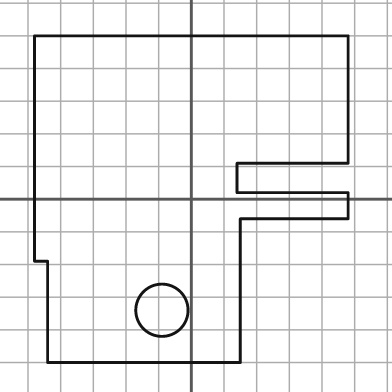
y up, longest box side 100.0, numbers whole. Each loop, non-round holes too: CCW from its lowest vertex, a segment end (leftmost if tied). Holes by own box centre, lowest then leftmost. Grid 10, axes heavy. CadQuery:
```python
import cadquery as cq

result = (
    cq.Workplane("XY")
    .moveTo(-44.0, -50.0)
    .lineTo(15.0, -50.0)
    .lineTo(15.0, -6.0)
    .lineTo(48.0, -6.0)
    .lineTo(48.0, 2.0)
    .lineTo(14.0, 2.0)
    .lineTo(14.0, 11.0)
    .lineTo(48.0, 11.0)
    .lineTo(48.0, 50.0)
    .lineTo(-48.0, 50.0)
    .lineTo(-48.0, -19.0)
    .lineTo(-44.0, -19.0)
    .close()
    .moveTo(-9.0, -34.0)
    .circle(8.0)
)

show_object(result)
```